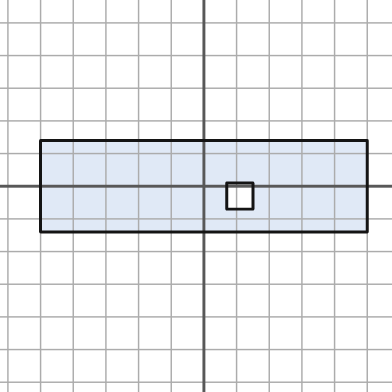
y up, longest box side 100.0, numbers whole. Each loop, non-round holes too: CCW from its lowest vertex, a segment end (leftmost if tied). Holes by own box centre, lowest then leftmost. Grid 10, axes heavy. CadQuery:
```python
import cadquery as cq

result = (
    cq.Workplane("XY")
    .moveTo(-50.0, -14.0)
    .lineTo(50.0, -14.0)
    .lineTo(50.0, 14.0)
    .lineTo(-50.0, 14.0)
    .close()
    .moveTo(7.0, -7.0)
    .lineTo(15.0, -7.0)
    .lineTo(15.0, 1.0)
    .lineTo(7.0, 1.0)
    .close()
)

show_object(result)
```